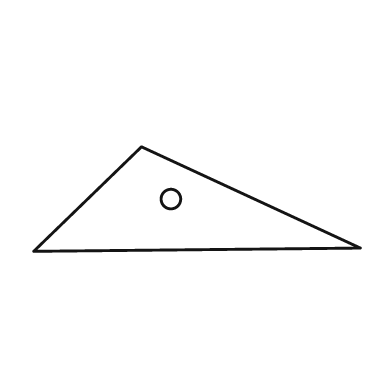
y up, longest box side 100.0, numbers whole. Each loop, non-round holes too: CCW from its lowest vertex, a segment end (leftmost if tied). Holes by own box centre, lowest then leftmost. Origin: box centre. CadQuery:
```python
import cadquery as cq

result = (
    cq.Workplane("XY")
    .moveTo(-50.0, -16.0)
    .lineTo(50.0, -15.0)
    .lineTo(-17.0, 16.0)
    .close()
    .moveTo(-8.0, 0.0)
    .circle(3.0)
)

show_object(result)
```